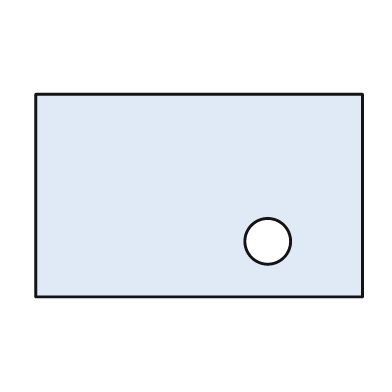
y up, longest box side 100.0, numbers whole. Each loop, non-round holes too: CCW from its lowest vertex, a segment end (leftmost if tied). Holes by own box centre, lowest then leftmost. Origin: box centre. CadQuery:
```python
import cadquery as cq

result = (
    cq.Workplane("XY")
    .moveTo(-50.0, -31.0)
    .lineTo(50.0, -31.0)
    .lineTo(50.0, 31.0)
    .lineTo(-50.0, 31.0)
    .close()
    .moveTo(21.0, -14.0)
    .circle(7.0)
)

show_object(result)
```